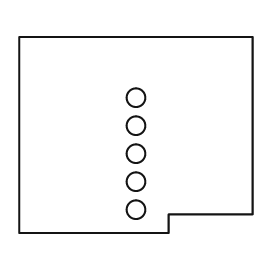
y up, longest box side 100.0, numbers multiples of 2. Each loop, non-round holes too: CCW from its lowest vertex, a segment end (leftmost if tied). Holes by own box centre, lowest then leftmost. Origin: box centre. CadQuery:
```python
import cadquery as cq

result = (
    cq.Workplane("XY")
    .moveTo(-50.0, -42.0)
    .lineTo(14.0, -42.0)
    .lineTo(14.0, -34.0)
    .lineTo(50.0, -34.0)
    .lineTo(50.0, 42.0)
    .lineTo(-50.0, 42.0)
    .close()
    .moveTo(0.0, -32.0)
    .circle(4.0)
    .moveTo(0.0, -20.0)
    .circle(4.0)
    .moveTo(0.0, -8.0)
    .circle(4.0)
    .moveTo(0.0, 4.0)
    .circle(4.0)
    .moveTo(0.0, 16.0)
    .circle(4.0)
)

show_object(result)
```